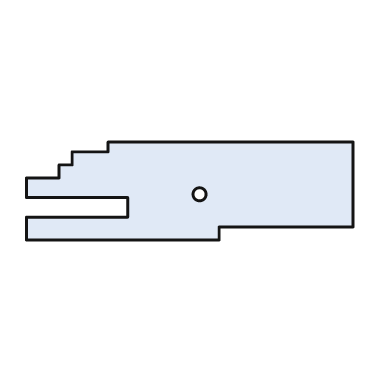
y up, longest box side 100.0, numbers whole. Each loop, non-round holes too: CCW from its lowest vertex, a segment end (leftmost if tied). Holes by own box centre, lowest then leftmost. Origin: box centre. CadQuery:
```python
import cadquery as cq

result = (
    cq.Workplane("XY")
    .moveTo(-50.0, -15.0)
    .lineTo(9.0, -15.0)
    .lineTo(9.0, -11.0)
    .lineTo(50.0, -11.0)
    .lineTo(50.0, 15.0)
    .lineTo(-25.0, 15.0)
    .lineTo(-25.0, 12.0)
    .lineTo(-36.0, 12.0)
    .lineTo(-36.0, 8.0)
    .lineTo(-40.0, 8.0)
    .lineTo(-40.0, 4.0)
    .lineTo(-50.0, 4.0)
    .lineTo(-50.0, -2.0)
    .lineTo(-19.0, -2.0)
    .lineTo(-19.0, -8.0)
    .lineTo(-50.0, -8.0)
    .close()
    .moveTo(3.0, -1.0)
    .circle(2.0)
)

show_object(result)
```